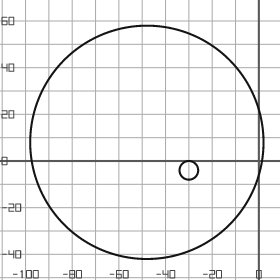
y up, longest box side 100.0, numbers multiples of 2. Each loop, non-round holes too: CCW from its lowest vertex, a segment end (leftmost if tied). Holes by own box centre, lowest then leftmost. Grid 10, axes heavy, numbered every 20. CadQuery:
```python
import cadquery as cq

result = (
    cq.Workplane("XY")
    .moveTo(-48.0, 8.0)
    .circle(50.0)
    .moveTo(-30.0, -4.0)
    .circle(4.0)
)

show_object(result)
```